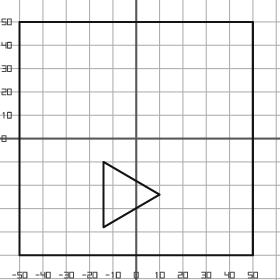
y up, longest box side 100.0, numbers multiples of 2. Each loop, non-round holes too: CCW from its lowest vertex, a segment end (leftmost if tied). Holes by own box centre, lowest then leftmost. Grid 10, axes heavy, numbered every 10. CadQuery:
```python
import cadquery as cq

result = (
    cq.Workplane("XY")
    .moveTo(-50.0, -50.0)
    .lineTo(50.0, -50.0)
    .lineTo(50.0, 50.0)
    .lineTo(-50.0, 50.0)
    .close()
    .moveTo(-14.0, -38.0)
    .lineTo(10.0, -24.0)
    .lineTo(-14.0, -10.0)
    .close()
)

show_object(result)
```